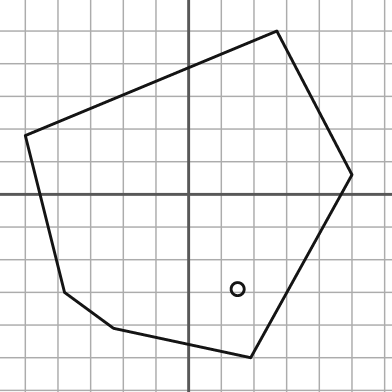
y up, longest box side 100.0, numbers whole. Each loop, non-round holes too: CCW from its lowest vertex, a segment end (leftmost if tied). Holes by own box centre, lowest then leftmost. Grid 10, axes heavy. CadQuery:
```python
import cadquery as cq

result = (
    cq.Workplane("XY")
    .moveTo(19.0, -50.0)
    .lineTo(50.0, 6.0)
    .lineTo(27.0, 50.0)
    .lineTo(-50.0, 18.0)
    .lineTo(-38.0, -30.0)
    .lineTo(-23.0, -41.0)
    .close()
    .moveTo(15.0, -29.0)
    .circle(2.0)
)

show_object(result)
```